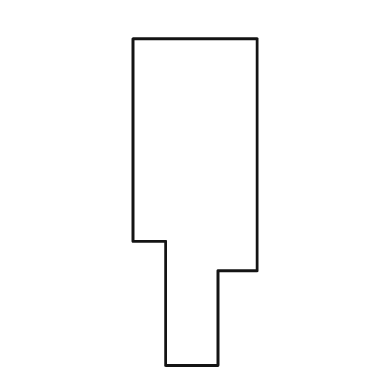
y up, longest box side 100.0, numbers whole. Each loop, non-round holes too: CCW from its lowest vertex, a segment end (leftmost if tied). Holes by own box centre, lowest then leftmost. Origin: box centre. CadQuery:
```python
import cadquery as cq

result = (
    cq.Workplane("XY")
    .moveTo(-9.0, -50.0)
    .lineTo(7.0, -50.0)
    .lineTo(7.0, -21.0)
    .lineTo(19.0, -21.0)
    .lineTo(19.0, 50.0)
    .lineTo(-19.0, 50.0)
    .lineTo(-19.0, -12.0)
    .lineTo(-9.0, -12.0)
    .close()
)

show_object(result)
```